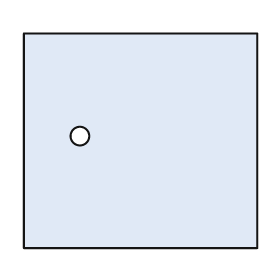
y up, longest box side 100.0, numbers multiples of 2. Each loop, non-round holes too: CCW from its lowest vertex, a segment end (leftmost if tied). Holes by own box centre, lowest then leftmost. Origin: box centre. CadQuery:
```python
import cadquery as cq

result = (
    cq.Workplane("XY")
    .moveTo(-50.0, -46.0)
    .lineTo(50.0, -46.0)
    .lineTo(50.0, 46.0)
    .lineTo(-50.0, 46.0)
    .close()
    .moveTo(-26.0, 2.0)
    .circle(4.0)
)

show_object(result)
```